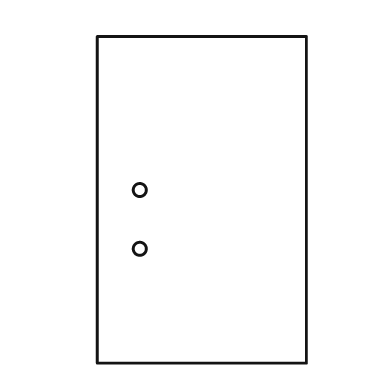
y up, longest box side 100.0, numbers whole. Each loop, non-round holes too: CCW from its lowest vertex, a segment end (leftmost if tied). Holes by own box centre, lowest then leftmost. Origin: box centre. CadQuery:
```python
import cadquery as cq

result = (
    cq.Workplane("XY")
    .moveTo(-32.0, -50.0)
    .lineTo(32.0, -50.0)
    .lineTo(32.0, 50.0)
    .lineTo(-32.0, 50.0)
    .close()
    .moveTo(-19.0, -15.0)
    .circle(2.0)
    .moveTo(-19.0, 3.0)
    .circle(2.0)
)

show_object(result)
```